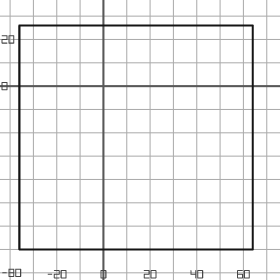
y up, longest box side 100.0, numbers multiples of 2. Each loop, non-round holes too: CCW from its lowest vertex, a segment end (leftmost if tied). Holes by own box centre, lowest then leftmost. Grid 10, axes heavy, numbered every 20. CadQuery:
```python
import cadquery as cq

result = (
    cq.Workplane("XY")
    .moveTo(-36.0, -70.0)
    .lineTo(64.0, -70.0)
    .lineTo(64.0, 26.0)
    .lineTo(-36.0, 26.0)
    .close()
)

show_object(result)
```